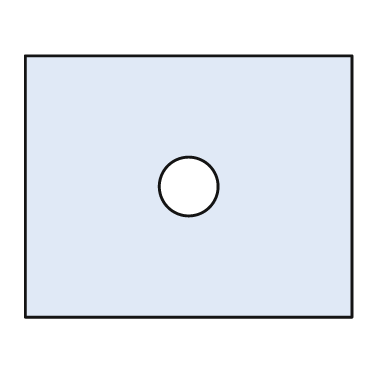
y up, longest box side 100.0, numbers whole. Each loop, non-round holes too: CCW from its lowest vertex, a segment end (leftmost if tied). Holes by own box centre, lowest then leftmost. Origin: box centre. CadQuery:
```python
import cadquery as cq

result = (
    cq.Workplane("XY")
    .moveTo(-50.0, -40.0)
    .lineTo(50.0, -40.0)
    .lineTo(50.0, 40.0)
    .lineTo(-50.0, 40.0)
    .close()
    .moveTo(0.0, 0.0)
    .circle(9.0)
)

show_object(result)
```